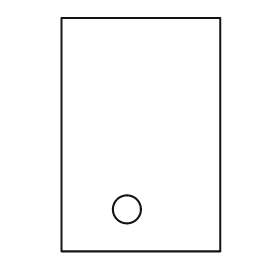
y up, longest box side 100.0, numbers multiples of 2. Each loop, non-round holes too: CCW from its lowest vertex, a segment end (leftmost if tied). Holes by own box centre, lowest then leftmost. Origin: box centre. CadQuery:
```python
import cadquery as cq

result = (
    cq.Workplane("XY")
    .moveTo(-34.0, -50.0)
    .lineTo(34.0, -50.0)
    .lineTo(34.0, 50.0)
    .lineTo(-34.0, 50.0)
    .close()
    .moveTo(-6.0, -32.0)
    .circle(6.0)
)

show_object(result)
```